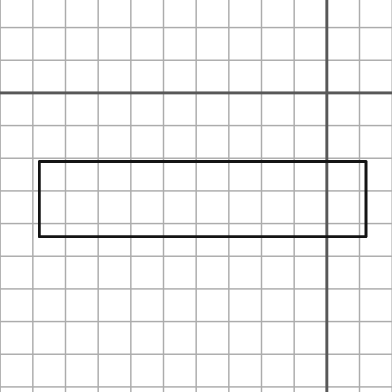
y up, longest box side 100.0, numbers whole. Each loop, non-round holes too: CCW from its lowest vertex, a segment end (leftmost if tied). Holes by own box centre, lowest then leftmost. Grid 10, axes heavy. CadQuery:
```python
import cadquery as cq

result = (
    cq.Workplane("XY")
    .moveTo(-88.0, -44.0)
    .lineTo(12.0, -44.0)
    .lineTo(12.0, -21.0)
    .lineTo(-88.0, -21.0)
    .close()
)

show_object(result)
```